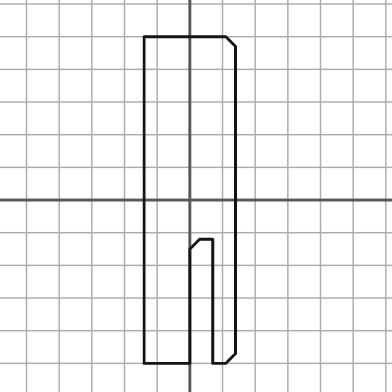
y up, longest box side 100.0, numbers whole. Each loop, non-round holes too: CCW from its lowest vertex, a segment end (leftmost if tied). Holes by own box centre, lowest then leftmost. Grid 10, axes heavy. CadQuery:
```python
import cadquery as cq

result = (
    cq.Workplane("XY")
    .moveTo(-14.0, -50.0)
    .lineTo(0.0, -50.0)
    .lineTo(0.0, -15.0)
    .lineTo(3.0, -12.0)
    .lineTo(7.0, -12.0)
    .lineTo(7.0, -50.0)
    .lineTo(11.0, -50.0)
    .lineTo(14.0, -47.0)
    .lineTo(14.0, 47.0)
    .lineTo(11.0, 50.0)
    .lineTo(-14.0, 50.0)
    .close()
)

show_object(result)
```